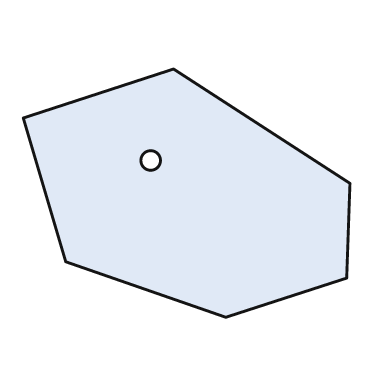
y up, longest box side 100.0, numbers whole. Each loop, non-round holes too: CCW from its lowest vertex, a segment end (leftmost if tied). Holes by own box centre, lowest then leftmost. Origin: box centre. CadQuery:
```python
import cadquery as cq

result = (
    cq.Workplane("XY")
    .moveTo(12.0, -38.0)
    .lineTo(49.0, -26.0)
    .lineTo(50.0, 3.0)
    .lineTo(-4.0, 38.0)
    .lineTo(-50.0, 23.0)
    .lineTo(-37.0, -21.0)
    .close()
    .moveTo(-11.0, 10.0)
    .circle(3.0)
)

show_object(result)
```